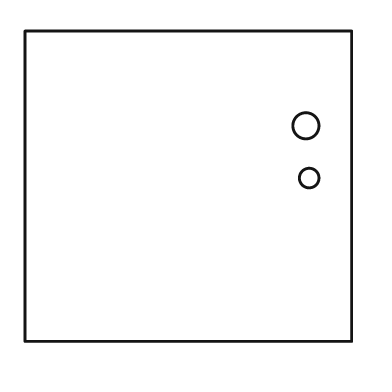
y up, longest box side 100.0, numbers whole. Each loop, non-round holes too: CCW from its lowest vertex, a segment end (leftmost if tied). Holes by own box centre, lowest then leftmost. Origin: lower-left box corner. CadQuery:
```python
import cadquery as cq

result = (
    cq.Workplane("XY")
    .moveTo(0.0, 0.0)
    .lineTo(100.0, 0.0)
    .lineTo(100.0, 95.0)
    .lineTo(0.0, 95.0)
    .close()
    .moveTo(87.0, 50.0)
    .circle(3.0)
    .moveTo(86.0, 66.0)
    .circle(4.0)
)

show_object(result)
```